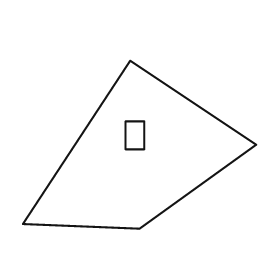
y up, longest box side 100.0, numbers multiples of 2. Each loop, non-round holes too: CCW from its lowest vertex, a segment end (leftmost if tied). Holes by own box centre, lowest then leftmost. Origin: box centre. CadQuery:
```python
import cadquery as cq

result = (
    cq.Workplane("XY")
    .moveTo(0.0, -36.0)
    .lineTo(50.0, 0.0)
    .lineTo(-4.0, 36.0)
    .lineTo(-50.0, -34.0)
    .close()
    .moveTo(-6.0, -2.0)
    .lineTo(2.0, -2.0)
    .lineTo(2.0, 10.0)
    .lineTo(-6.0, 10.0)
    .close()
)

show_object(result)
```